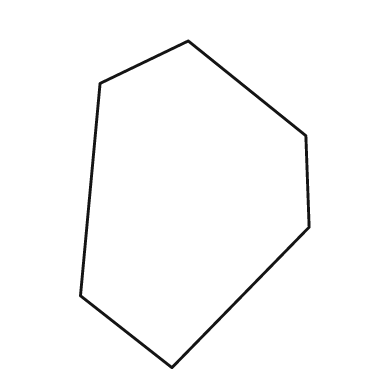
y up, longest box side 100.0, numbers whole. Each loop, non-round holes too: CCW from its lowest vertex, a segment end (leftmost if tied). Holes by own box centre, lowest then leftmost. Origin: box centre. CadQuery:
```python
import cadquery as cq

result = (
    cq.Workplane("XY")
    .moveTo(-7.0, -50.0)
    .lineTo(35.0, -7.0)
    .lineTo(34.0, 21.0)
    .lineTo(-2.0, 50.0)
    .lineTo(-29.0, 37.0)
    .lineTo(-35.0, -28.0)
    .close()
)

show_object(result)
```